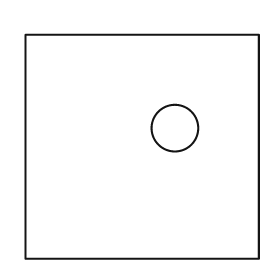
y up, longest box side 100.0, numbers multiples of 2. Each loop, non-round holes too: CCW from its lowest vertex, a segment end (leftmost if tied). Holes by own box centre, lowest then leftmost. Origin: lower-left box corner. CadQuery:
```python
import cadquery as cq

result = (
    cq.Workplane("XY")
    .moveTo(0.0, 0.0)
    .lineTo(100.0, 0.0)
    .lineTo(100.0, 96.0)
    .lineTo(0.0, 96.0)
    .close()
    .moveTo(64.0, 56.0)
    .circle(10.0)
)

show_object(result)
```